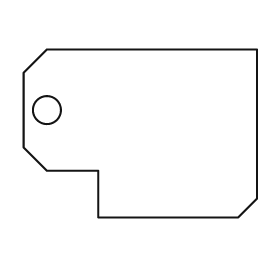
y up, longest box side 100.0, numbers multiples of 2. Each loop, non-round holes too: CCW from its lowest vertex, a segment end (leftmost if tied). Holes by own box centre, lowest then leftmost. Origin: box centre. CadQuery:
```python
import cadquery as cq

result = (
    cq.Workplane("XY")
    .moveTo(-18.0, -36.0)
    .lineTo(42.0, -36.0)
    .lineTo(50.0, -28.0)
    .lineTo(50.0, 36.0)
    .lineTo(-40.0, 36.0)
    .lineTo(-50.0, 26.0)
    .lineTo(-50.0, -6.0)
    .lineTo(-40.0, -16.0)
    .lineTo(-18.0, -16.0)
    .close()
    .moveTo(-40.0, 10.0)
    .circle(6.0)
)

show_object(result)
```